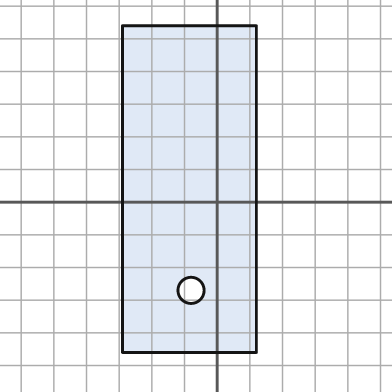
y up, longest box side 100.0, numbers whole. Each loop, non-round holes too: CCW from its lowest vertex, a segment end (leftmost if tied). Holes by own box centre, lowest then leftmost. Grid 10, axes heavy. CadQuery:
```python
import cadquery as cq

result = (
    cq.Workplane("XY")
    .moveTo(-29.0, -46.0)
    .lineTo(12.0, -46.0)
    .lineTo(12.0, 54.0)
    .lineTo(-29.0, 54.0)
    .close()
    .moveTo(-8.0, -27.0)
    .circle(4.0)
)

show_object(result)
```